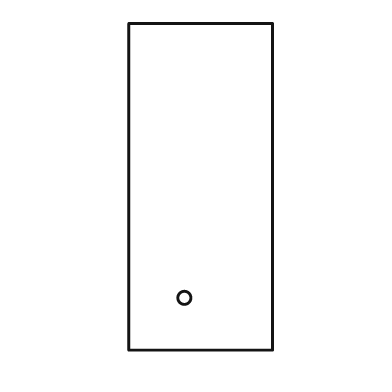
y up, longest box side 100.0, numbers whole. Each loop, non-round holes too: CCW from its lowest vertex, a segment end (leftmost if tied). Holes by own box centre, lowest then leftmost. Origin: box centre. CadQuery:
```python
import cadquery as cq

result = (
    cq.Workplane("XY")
    .moveTo(-22.0, -50.0)
    .lineTo(22.0, -50.0)
    .lineTo(22.0, 50.0)
    .lineTo(-22.0, 50.0)
    .close()
    .moveTo(-5.0, -34.0)
    .circle(2.0)
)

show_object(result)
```